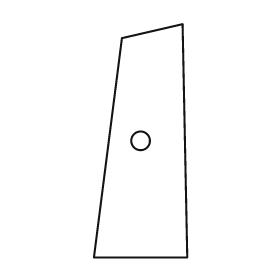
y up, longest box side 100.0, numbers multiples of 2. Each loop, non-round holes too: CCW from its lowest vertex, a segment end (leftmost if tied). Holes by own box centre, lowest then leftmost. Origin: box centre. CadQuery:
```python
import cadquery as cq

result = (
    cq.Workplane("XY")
    .moveTo(-20.0, -50.0)
    .lineTo(20.0, -50.0)
    .lineTo(18.0, 50.0)
    .lineTo(-8.0, 44.0)
    .close()
    .moveTo(0.0, 0.0)
    .circle(4.0)
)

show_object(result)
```